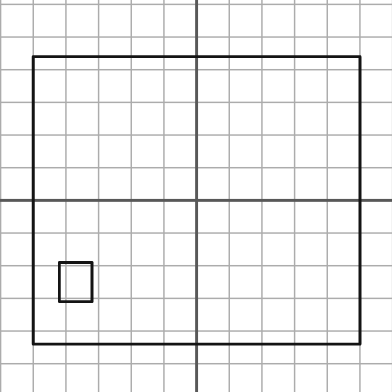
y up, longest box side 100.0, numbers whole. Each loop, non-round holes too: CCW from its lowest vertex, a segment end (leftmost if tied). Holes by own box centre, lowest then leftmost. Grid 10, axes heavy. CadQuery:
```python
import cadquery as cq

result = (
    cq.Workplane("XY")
    .moveTo(-50.0, -44.0)
    .lineTo(50.0, -44.0)
    .lineTo(50.0, 44.0)
    .lineTo(-50.0, 44.0)
    .close()
    .moveTo(-42.0, -31.0)
    .lineTo(-32.0, -31.0)
    .lineTo(-32.0, -19.0)
    .lineTo(-42.0, -19.0)
    .close()
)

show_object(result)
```